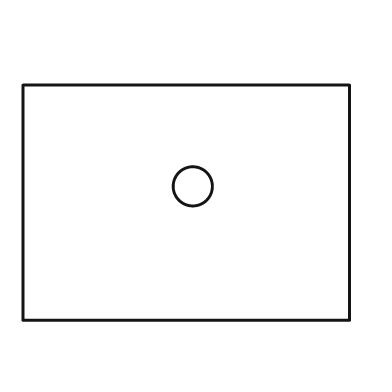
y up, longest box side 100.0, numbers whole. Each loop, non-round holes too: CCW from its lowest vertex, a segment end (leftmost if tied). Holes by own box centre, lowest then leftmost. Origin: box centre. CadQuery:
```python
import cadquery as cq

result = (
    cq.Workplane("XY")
    .moveTo(-50.0, -36.0)
    .lineTo(50.0, -36.0)
    .lineTo(50.0, 36.0)
    .lineTo(-50.0, 36.0)
    .close()
    .moveTo(2.0, 5.0)
    .circle(6.0)
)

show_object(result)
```